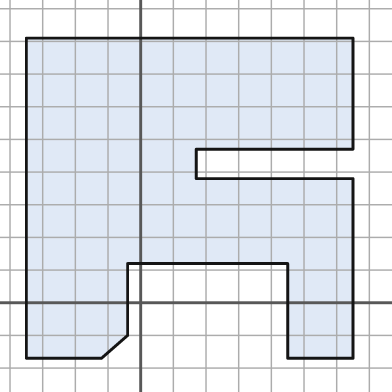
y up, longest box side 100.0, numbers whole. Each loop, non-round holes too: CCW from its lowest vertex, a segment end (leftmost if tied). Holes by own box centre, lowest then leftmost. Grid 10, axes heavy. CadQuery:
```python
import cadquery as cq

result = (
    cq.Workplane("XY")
    .moveTo(-35.0, -17.0)
    .lineTo(-12.0, -17.0)
    .lineTo(-4.0, -10.0)
    .lineTo(-4.0, 12.0)
    .lineTo(45.0, 12.0)
    .lineTo(45.0, -17.0)
    .lineTo(65.0, -17.0)
    .lineTo(65.0, 38.0)
    .lineTo(17.0, 38.0)
    .lineTo(17.0, 47.0)
    .lineTo(65.0, 47.0)
    .lineTo(65.0, 81.0)
    .lineTo(-35.0, 81.0)
    .close()
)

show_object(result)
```